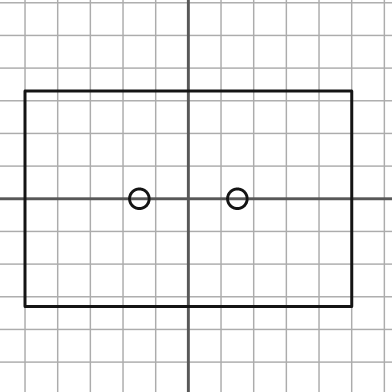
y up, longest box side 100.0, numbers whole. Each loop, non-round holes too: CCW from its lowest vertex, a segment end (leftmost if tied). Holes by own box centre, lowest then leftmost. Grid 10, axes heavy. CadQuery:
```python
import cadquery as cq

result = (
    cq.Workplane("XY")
    .moveTo(-50.0, -33.0)
    .lineTo(50.0, -33.0)
    .lineTo(50.0, 33.0)
    .lineTo(-50.0, 33.0)
    .close()
    .moveTo(-15.0, 0.0)
    .circle(3.0)
    .moveTo(15.0, 0.0)
    .circle(3.0)
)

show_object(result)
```